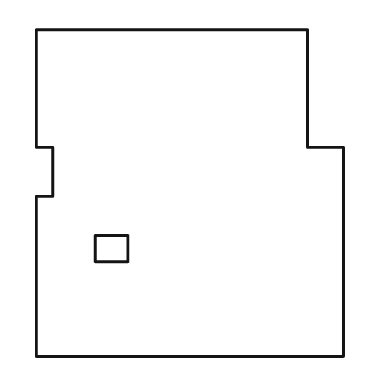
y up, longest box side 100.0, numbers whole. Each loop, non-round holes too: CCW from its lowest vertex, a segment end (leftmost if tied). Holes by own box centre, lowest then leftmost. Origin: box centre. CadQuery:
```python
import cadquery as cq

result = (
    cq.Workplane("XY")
    .moveTo(-47.0, -50.0)
    .lineTo(47.0, -50.0)
    .lineTo(47.0, 14.0)
    .lineTo(36.0, 14.0)
    .lineTo(36.0, 50.0)
    .lineTo(-47.0, 50.0)
    .lineTo(-47.0, 14.0)
    .lineTo(-42.0, 14.0)
    .lineTo(-42.0, -1.0)
    .lineTo(-47.0, -1.0)
    .close()
    .moveTo(-29.0, -21.0)
    .lineTo(-19.0, -21.0)
    .lineTo(-19.0, -13.0)
    .lineTo(-29.0, -13.0)
    .close()
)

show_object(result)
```